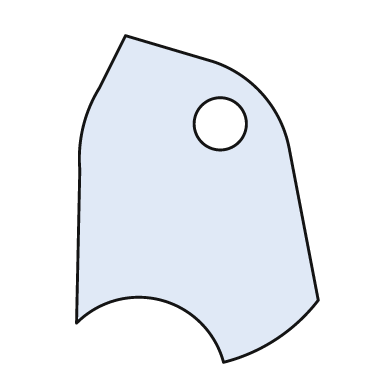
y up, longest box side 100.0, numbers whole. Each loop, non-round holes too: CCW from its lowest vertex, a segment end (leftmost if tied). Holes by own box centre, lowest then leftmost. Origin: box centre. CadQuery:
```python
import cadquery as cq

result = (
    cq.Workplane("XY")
    .moveTo(8.0, -50.0)
    .threePointArc((24.0, -43.0), (37.0, -31.0))
    .lineTo(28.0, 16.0)
    .threePointArc((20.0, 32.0), (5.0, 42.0))
    .lineTo(-22.0, 50.0)
    .lineTo(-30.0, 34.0)
    .threePointArc((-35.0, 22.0), (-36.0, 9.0))
    .lineTo(-37.0, -38.0)
    .threePointArc((-11.0, -31.0), (8.0, -50.0))
    .close()
    .moveTo(7.0, 23.0)
    .circle(8.0)
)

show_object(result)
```